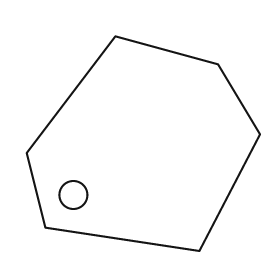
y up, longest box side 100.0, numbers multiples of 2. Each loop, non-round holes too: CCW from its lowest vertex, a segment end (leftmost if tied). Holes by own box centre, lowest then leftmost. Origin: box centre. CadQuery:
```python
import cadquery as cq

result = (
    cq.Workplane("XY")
    .moveTo(24.0, -46.0)
    .lineTo(50.0, 4.0)
    .lineTo(32.0, 34.0)
    .lineTo(-12.0, 46.0)
    .lineTo(-50.0, -4.0)
    .lineTo(-42.0, -36.0)
    .close()
    .moveTo(-30.0, -22.0)
    .circle(6.0)
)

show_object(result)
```